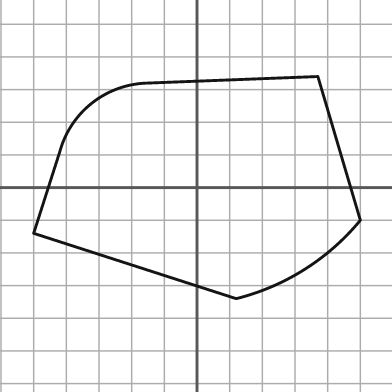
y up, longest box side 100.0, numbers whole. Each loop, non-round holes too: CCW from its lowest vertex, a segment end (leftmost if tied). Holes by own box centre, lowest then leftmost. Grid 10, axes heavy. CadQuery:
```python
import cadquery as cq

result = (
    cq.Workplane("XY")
    .moveTo(12.0, -34.0)
    .threePointArc((33.0, -25.0), (50.0, -10.0))
    .lineTo(37.0, 34.0)
    .lineTo(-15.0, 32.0)
    .threePointArc((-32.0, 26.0), (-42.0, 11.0))
    .lineTo(-50.0, -14.0)
    .close()
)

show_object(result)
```